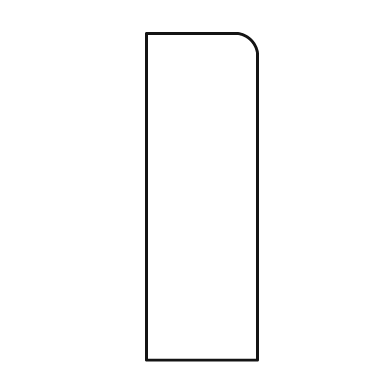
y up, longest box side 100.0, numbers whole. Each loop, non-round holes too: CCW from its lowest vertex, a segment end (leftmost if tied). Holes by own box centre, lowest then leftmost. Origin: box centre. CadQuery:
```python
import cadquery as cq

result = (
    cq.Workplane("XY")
    .moveTo(-17.0, -50.0)
    .lineTo(17.0, -50.0)
    .lineTo(17.0, 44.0)
    .threePointArc((15.0, 48.0), (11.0, 50.0))
    .lineTo(-17.0, 50.0)
    .close()
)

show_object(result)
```